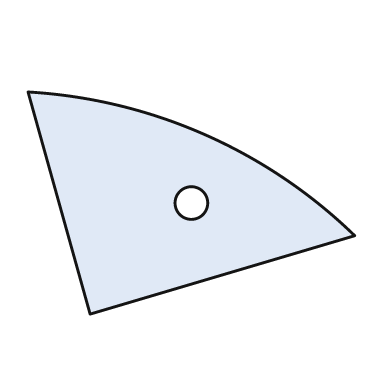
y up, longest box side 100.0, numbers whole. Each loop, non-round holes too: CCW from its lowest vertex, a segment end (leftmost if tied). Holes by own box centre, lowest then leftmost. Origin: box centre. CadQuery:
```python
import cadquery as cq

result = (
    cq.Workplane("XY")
    .moveTo(-31.0, -34.0)
    .lineTo(50.0, -10.0)
    .threePointArc((4.0, 21.0), (-50.0, 34.0))
    .close()
    .moveTo(0.0, 0.0)
    .circle(5.0)
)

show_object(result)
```